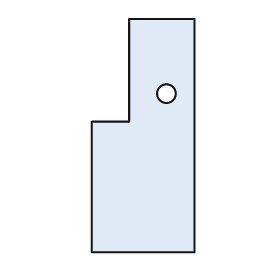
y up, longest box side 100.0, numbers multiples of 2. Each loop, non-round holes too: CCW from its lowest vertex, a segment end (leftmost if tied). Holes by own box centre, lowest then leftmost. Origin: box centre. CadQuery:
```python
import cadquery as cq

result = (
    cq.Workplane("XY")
    .moveTo(-22.0, -50.0)
    .lineTo(22.0, -50.0)
    .lineTo(22.0, 50.0)
    .lineTo(-6.0, 50.0)
    .lineTo(-6.0, 6.0)
    .lineTo(-22.0, 6.0)
    .close()
    .moveTo(10.0, 18.0)
    .circle(4.0)
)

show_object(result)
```